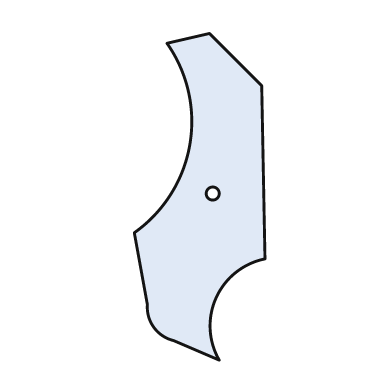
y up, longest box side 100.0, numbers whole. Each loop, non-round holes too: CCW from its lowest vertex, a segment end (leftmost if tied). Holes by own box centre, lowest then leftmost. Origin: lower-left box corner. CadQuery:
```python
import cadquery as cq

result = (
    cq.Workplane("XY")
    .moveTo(26.0, 0.0)
    .threePointArc((25.0, 19.0), (40.0, 31.0))
    .lineTo(39.0, 84.0)
    .lineTo(23.0, 100.0)
    .lineTo(10.0, 97.0)
    .threePointArc((17.0, 66.0), (0.0, 39.0))
    .lineTo(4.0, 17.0)
    .threePointArc((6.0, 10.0), (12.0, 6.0))
    .close()
    .moveTo(24.0, 51.0)
    .circle(2.0)
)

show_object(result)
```